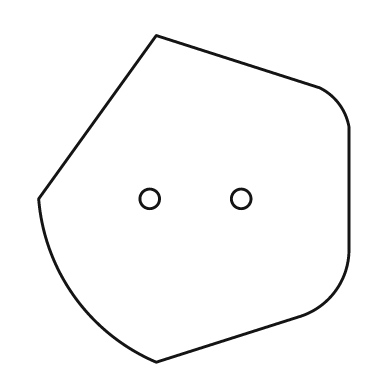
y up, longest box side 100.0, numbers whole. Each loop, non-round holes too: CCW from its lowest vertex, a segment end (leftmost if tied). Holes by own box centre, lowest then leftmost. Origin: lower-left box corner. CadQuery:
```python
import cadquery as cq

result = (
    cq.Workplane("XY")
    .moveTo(36.0, 0.0)
    .lineTo(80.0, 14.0)
    .threePointArc((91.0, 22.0), (95.0, 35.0))
    .lineTo(95.0, 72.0)
    .threePointArc((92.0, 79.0), (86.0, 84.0))
    .lineTo(36.0, 100.0)
    .lineTo(0.0, 50.0)
    .threePointArc((11.0, 20.0), (36.0, 0.0))
    .close()
    .moveTo(34.0, 50.0)
    .circle(3.0)
    .moveTo(62.0, 50.0)
    .circle(3.0)
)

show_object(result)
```